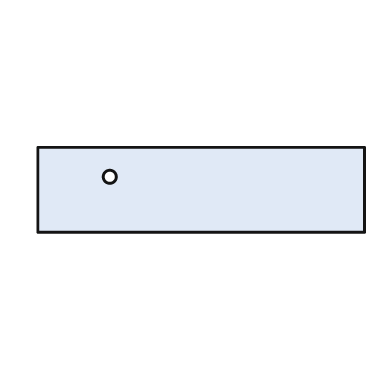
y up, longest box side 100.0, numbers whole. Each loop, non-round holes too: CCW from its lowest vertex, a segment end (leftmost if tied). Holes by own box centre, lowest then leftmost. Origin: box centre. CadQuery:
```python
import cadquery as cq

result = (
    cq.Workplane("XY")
    .moveTo(-50.0, -13.0)
    .lineTo(50.0, -13.0)
    .lineTo(50.0, 13.0)
    .lineTo(-50.0, 13.0)
    .close()
    .moveTo(-28.0, 4.0)
    .circle(2.0)
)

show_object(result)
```